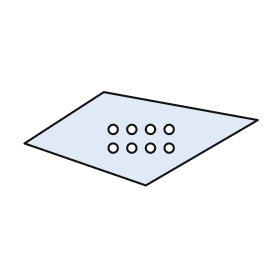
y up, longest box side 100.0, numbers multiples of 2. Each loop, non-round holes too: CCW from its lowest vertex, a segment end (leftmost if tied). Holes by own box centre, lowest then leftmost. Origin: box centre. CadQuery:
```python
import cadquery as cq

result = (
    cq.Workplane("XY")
    .moveTo(2.0, -20.0)
    .lineTo(50.0, 8.0)
    .lineTo(-16.0, 20.0)
    .lineTo(-50.0, -2.0)
    .close()
    .moveTo(-12.0, -4.0)
    .circle(2.0)
    .moveTo(-4.0, -4.0)
    .circle(2.0)
    .moveTo(4.0, -4.0)
    .circle(2.0)
    .moveTo(12.0, -4.0)
    .circle(2.0)
    .moveTo(-12.0, 4.0)
    .circle(2.0)
    .moveTo(-4.0, 4.0)
    .circle(2.0)
    .moveTo(4.0, 4.0)
    .circle(2.0)
    .moveTo(12.0, 4.0)
    .circle(2.0)
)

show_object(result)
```